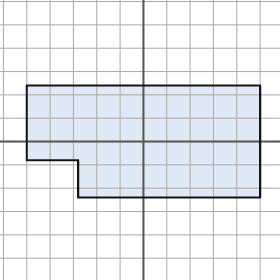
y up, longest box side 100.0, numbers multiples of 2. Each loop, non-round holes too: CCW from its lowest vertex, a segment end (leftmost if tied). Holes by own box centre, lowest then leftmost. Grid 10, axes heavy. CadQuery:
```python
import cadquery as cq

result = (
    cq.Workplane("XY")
    .moveTo(-28.0, -24.0)
    .lineTo(50.0, -24.0)
    .lineTo(50.0, 24.0)
    .lineTo(-50.0, 24.0)
    .lineTo(-50.0, -8.0)
    .lineTo(-28.0, -8.0)
    .close()
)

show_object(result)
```